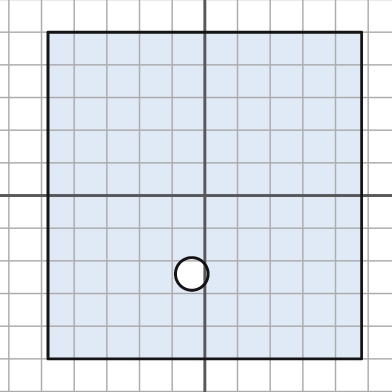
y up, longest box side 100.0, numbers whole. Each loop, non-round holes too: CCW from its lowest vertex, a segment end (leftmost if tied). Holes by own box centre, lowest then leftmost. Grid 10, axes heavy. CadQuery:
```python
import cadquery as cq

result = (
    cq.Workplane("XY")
    .moveTo(-48.0, -50.0)
    .lineTo(48.0, -50.0)
    .lineTo(48.0, 50.0)
    .lineTo(-48.0, 50.0)
    .close()
    .moveTo(-4.0, -24.0)
    .circle(5.0)
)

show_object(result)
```